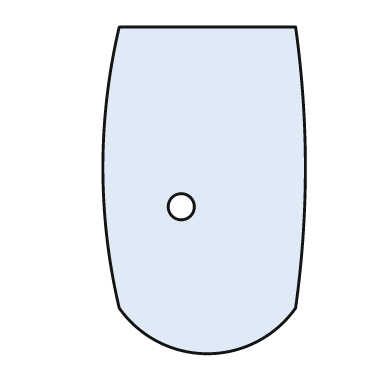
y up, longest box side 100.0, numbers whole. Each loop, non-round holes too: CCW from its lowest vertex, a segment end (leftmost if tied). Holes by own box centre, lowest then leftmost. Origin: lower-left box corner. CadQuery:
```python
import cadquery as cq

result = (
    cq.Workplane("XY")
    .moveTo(5.0, 14.0)
    .threePointArc((32.0, 0.0), (59.0, 14.0))
    .threePointArc((62.0, 57.0), (59.0, 100.0))
    .lineTo(5.0, 100.0)
    .threePointArc((0.0, 57.0), (5.0, 14.0))
    .close()
    .moveTo(24.0, 45.0)
    .circle(4.0)
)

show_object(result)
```